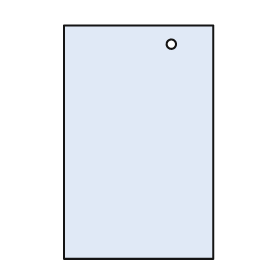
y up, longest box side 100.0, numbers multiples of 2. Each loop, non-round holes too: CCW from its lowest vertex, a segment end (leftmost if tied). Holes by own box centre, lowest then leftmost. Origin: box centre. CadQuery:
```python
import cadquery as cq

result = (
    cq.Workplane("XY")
    .moveTo(-32.0, -50.0)
    .lineTo(32.0, -50.0)
    .lineTo(32.0, 50.0)
    .lineTo(-32.0, 50.0)
    .close()
    .moveTo(14.0, 42.0)
    .circle(2.0)
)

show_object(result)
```